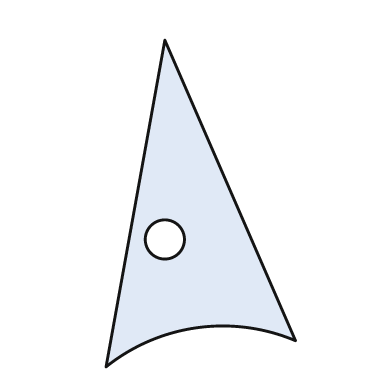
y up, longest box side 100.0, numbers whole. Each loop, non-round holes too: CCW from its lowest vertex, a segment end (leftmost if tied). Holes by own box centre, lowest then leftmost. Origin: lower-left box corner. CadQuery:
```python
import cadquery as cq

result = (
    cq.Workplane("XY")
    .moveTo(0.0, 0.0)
    .threePointArc((28.0, 12.0), (58.0, 8.0))
    .lineTo(18.0, 100.0)
    .close()
    .moveTo(18.0, 39.0)
    .circle(6.0)
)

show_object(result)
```